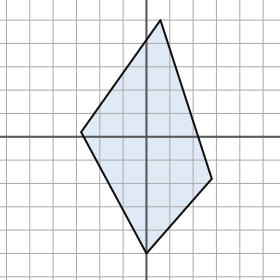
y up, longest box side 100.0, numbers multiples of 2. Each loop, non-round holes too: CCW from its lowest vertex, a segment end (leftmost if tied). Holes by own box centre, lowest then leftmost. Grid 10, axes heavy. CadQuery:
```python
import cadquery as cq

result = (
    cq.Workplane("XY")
    .moveTo(0.0, -50.0)
    .lineTo(28.0, -18.0)
    .lineTo(6.0, 50.0)
    .lineTo(-28.0, 2.0)
    .close()
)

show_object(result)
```